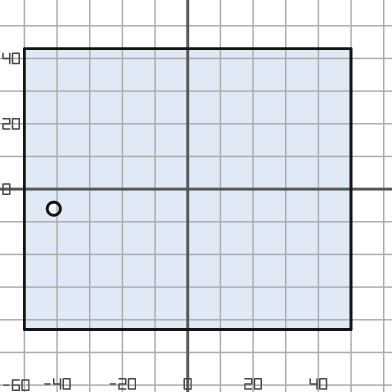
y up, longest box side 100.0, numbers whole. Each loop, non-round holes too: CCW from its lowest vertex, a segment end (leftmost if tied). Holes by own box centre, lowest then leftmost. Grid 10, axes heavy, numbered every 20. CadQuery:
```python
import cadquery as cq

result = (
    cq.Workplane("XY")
    .moveTo(-50.0, -43.0)
    .lineTo(50.0, -43.0)
    .lineTo(50.0, 43.0)
    .lineTo(-50.0, 43.0)
    .close()
    .moveTo(-41.0, -6.0)
    .circle(2.0)
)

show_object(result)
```